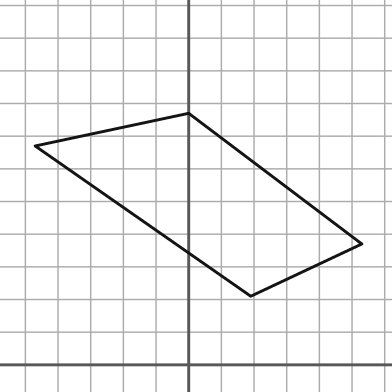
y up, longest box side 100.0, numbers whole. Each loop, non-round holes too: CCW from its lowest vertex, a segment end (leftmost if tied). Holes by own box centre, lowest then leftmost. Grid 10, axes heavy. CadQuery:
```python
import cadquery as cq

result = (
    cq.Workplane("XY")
    .moveTo(19.0, 21.0)
    .lineTo(53.0, 37.0)
    .lineTo(0.0, 77.0)
    .lineTo(-47.0, 67.0)
    .close()
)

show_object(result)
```